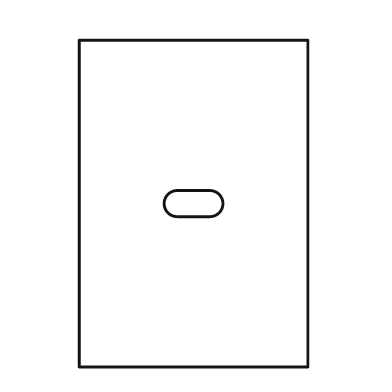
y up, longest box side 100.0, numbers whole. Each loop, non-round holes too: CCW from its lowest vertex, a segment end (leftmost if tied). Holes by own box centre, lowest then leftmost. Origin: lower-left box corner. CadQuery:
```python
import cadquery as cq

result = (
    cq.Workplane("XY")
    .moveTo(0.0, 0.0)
    .lineTo(70.0, 0.0)
    .lineTo(70.0, 100.0)
    .lineTo(0.0, 100.0)
    .close()
    .moveTo(30.0, 46.0)
    .lineTo(40.0, 46.0)
    .threePointArc((44.0, 50.0), (40.0, 54.0))
    .lineTo(30.0, 54.0)
    .threePointArc((26.0, 50.0), (30.0, 46.0))
    .close()
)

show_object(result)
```